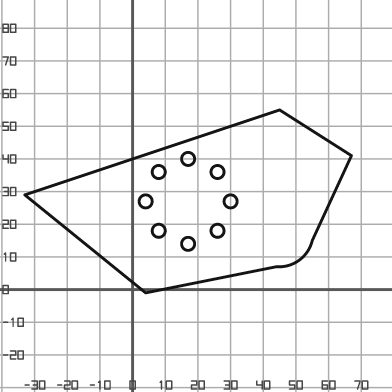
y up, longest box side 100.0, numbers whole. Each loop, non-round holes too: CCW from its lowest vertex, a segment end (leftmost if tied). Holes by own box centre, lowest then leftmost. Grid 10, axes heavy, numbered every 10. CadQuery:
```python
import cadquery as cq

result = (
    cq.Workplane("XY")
    .moveTo(4.0, -1.0)
    .lineTo(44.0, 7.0)
    .threePointArc((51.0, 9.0), (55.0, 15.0))
    .lineTo(67.0, 41.0)
    .lineTo(45.0, 55.0)
    .lineTo(-33.0, 29.0)
    .close()
    .moveTo(17.0, 14.0)
    .circle(2.0)
    .moveTo(8.0, 18.0)
    .circle(2.0)
    .moveTo(26.0, 18.0)
    .circle(2.0)
    .moveTo(4.0, 27.0)
    .circle(2.0)
    .moveTo(30.0, 27.0)
    .circle(2.0)
    .moveTo(8.0, 36.0)
    .circle(2.0)
    .moveTo(26.0, 36.0)
    .circle(2.0)
    .moveTo(17.0, 40.0)
    .circle(2.0)
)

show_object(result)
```